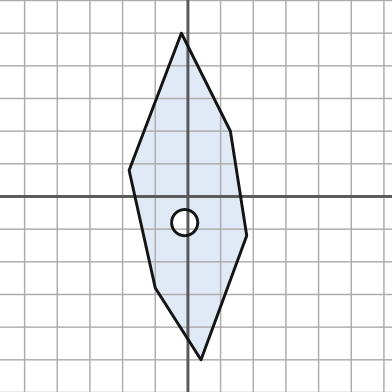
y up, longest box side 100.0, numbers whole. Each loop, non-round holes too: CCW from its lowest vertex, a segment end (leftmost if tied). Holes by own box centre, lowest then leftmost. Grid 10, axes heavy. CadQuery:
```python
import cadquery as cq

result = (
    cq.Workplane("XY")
    .moveTo(4.0, -50.0)
    .lineTo(18.0, -12.0)
    .lineTo(13.0, 20.0)
    .lineTo(-2.0, 50.0)
    .lineTo(-18.0, 8.0)
    .lineTo(-10.0, -28.0)
    .close()
    .moveTo(-1.0, -8.0)
    .circle(4.0)
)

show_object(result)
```